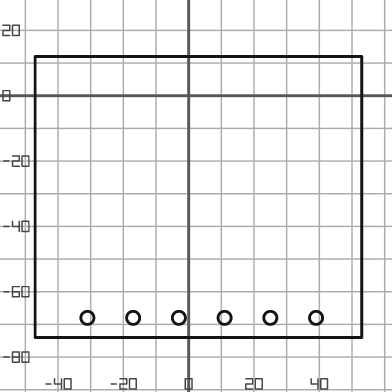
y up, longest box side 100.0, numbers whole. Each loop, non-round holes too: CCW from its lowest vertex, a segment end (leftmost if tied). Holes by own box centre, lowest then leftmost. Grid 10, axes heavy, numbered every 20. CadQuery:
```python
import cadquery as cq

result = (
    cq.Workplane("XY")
    .moveTo(-47.0, -74.0)
    .lineTo(53.0, -74.0)
    .lineTo(53.0, 12.0)
    .lineTo(-47.0, 12.0)
    .close()
    .moveTo(-31.0, -68.0)
    .circle(2.0)
    .moveTo(-17.0, -68.0)
    .circle(2.0)
    .moveTo(-3.0, -68.0)
    .circle(2.0)
    .moveTo(11.0, -68.0)
    .circle(2.0)
    .moveTo(25.0, -68.0)
    .circle(2.0)
    .moveTo(39.0, -68.0)
    .circle(2.0)
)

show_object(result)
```